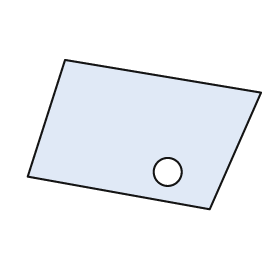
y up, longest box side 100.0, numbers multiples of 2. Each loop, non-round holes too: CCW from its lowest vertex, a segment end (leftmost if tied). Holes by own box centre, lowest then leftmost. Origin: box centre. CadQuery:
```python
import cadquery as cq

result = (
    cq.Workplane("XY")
    .moveTo(28.0, -32.0)
    .lineTo(50.0, 18.0)
    .lineTo(-34.0, 32.0)
    .lineTo(-50.0, -18.0)
    .close()
    .moveTo(10.0, -16.0)
    .circle(6.0)
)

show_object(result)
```